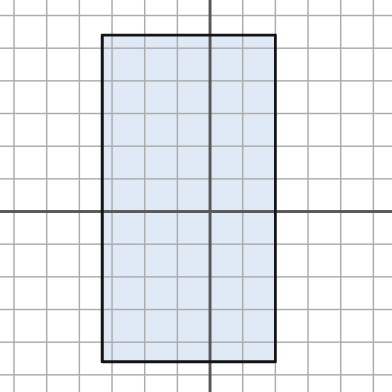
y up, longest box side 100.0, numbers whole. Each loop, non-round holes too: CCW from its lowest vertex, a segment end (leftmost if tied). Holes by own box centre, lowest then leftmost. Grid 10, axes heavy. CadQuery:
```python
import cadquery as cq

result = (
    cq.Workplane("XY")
    .moveTo(-33.0, -46.0)
    .lineTo(20.0, -46.0)
    .lineTo(20.0, 54.0)
    .lineTo(-33.0, 54.0)
    .close()
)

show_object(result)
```